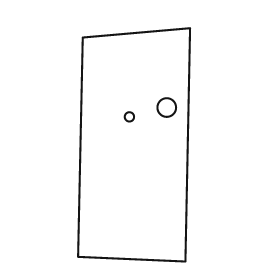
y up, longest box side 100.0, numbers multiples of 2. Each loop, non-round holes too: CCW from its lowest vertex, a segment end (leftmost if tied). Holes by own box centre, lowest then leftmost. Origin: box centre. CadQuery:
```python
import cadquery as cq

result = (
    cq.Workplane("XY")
    .moveTo(22.0, -50.0)
    .lineTo(24.0, 50.0)
    .lineTo(-22.0, 46.0)
    .lineTo(-24.0, -48.0)
    .close()
    .moveTo(-2.0, 12.0)
    .circle(2.0)
    .moveTo(14.0, 16.0)
    .circle(4.0)
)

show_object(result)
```